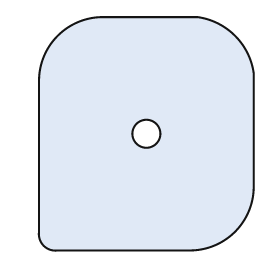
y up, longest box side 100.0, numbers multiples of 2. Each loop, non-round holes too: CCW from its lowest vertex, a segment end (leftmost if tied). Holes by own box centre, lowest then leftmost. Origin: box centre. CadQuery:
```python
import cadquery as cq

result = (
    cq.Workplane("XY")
    .moveTo(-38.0, -50.0)
    .lineTo(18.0, -50.0)
    .threePointArc((38.0, -42.0), (46.0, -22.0))
    .lineTo(46.0, 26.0)
    .threePointArc((38.0, 42.0), (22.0, 50.0))
    .lineTo(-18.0, 50.0)
    .threePointArc((-38.0, 42.0), (-46.0, 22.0))
    .lineTo(-46.0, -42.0)
    .threePointArc((-44.0, -48.0), (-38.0, -50.0))
    .close()
    .moveTo(0.0, 0.0)
    .circle(6.0)
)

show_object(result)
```